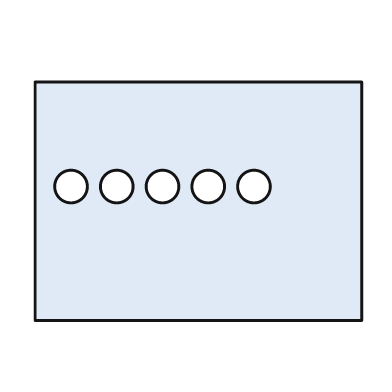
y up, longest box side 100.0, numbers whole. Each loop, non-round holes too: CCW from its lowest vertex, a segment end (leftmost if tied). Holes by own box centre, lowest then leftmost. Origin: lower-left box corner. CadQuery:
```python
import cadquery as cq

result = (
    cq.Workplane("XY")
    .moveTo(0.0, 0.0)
    .lineTo(100.0, 0.0)
    .lineTo(100.0, 73.0)
    .lineTo(0.0, 73.0)
    .close()
    .moveTo(11.0, 41.0)
    .circle(5.0)
    .moveTo(25.0, 41.0)
    .circle(5.0)
    .moveTo(39.0, 41.0)
    .circle(5.0)
    .moveTo(53.0, 41.0)
    .circle(5.0)
    .moveTo(67.0, 41.0)
    .circle(5.0)
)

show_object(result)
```